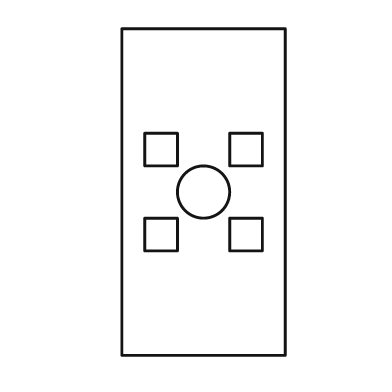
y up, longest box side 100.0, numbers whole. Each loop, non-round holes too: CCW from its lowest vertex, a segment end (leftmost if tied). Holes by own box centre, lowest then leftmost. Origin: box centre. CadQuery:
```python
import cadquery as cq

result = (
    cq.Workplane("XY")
    .moveTo(-25.0, -50.0)
    .lineTo(25.0, -50.0)
    .lineTo(25.0, 50.0)
    .lineTo(-25.0, 50.0)
    .close()
    .moveTo(-18.0, -18.0)
    .lineTo(-8.0, -18.0)
    .lineTo(-8.0, -8.0)
    .lineTo(-18.0, -8.0)
    .close()
    .moveTo(8.0, -18.0)
    .lineTo(18.0, -18.0)
    .lineTo(18.0, -8.0)
    .lineTo(8.0, -8.0)
    .close()
    .moveTo(0.0, 0.0)
    .circle(8.0)
    .moveTo(-18.0, 8.0)
    .lineTo(-8.0, 8.0)
    .lineTo(-8.0, 18.0)
    .lineTo(-18.0, 18.0)
    .close()
    .moveTo(8.0, 8.0)
    .lineTo(18.0, 8.0)
    .lineTo(18.0, 18.0)
    .lineTo(8.0, 18.0)
    .close()
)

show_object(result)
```